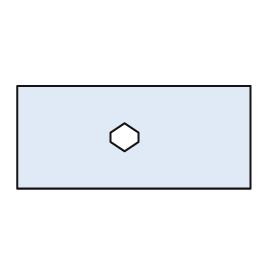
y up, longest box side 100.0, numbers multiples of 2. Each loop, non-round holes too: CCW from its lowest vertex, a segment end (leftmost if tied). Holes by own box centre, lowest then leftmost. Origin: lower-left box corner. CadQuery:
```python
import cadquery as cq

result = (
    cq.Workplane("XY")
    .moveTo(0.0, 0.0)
    .lineTo(100.0, 0.0)
    .lineTo(100.0, 44.0)
    .lineTo(0.0, 44.0)
    .close()
    .moveTo(46.0, 16.0)
    .lineTo(52.0, 20.0)
    .lineTo(52.0, 24.0)
    .lineTo(46.0, 28.0)
    .lineTo(40.0, 24.0)
    .lineTo(40.0, 20.0)
    .close()
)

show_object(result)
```